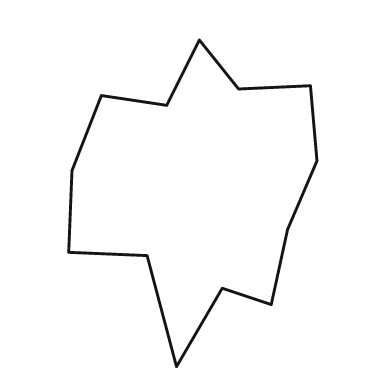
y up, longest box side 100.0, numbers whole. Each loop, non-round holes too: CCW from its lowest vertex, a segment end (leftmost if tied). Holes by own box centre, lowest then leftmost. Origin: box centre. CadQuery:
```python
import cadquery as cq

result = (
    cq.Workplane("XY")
    .moveTo(-5.0, -50.0)
    .lineTo(9.0, -26.0)
    .lineTo(24.0, -31.0)
    .lineTo(29.0, -8.0)
    .lineTo(38.0, 13.0)
    .lineTo(36.0, 36.0)
    .lineTo(14.0, 35.0)
    .lineTo(2.0, 50.0)
    .lineTo(-8.0, 30.0)
    .lineTo(-28.0, 33.0)
    .lineTo(-37.0, 10.0)
    .lineTo(-38.0, -15.0)
    .lineTo(-14.0, -16.0)
    .close()
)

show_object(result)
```